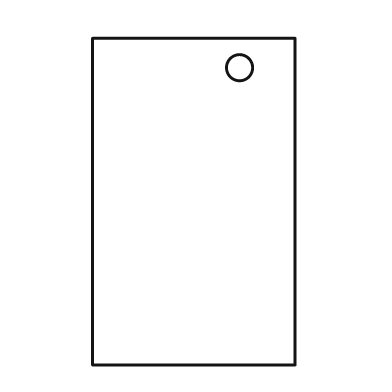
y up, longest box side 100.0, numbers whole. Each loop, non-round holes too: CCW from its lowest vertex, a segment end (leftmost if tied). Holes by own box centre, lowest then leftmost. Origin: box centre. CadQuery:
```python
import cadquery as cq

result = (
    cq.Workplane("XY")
    .moveTo(-31.0, -50.0)
    .lineTo(31.0, -50.0)
    .lineTo(31.0, 50.0)
    .lineTo(-31.0, 50.0)
    .close()
    .moveTo(14.0, 41.0)
    .circle(4.0)
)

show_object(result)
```